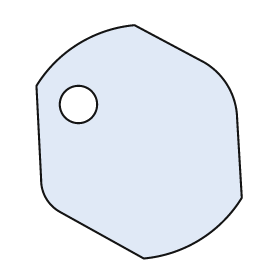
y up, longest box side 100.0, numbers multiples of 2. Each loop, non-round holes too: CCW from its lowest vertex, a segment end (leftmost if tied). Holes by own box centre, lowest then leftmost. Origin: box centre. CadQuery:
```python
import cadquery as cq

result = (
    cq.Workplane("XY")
    .moveTo(2.0, -50.0)
    .threePointArc((26.0, -42.0), (44.0, -24.0))
    .lineTo(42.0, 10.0)
    .threePointArc((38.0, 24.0), (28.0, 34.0))
    .lineTo(-2.0, 50.0)
    .threePointArc((-26.0, 42.0), (-44.0, 24.0))
    .lineTo(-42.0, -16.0)
    .threePointArc((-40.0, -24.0), (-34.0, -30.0))
    .close()
    .moveTo(-26.0, 16.0)
    .circle(8.0)
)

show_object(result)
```